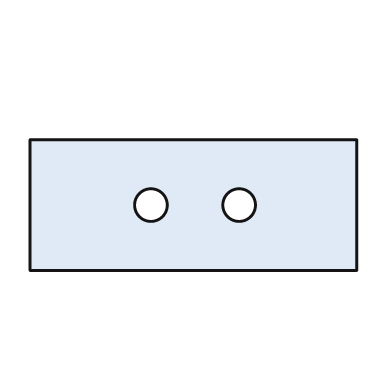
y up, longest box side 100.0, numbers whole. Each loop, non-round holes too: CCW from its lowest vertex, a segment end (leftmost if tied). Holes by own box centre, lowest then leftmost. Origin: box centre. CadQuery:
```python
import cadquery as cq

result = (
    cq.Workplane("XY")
    .moveTo(-50.0, -20.0)
    .lineTo(50.0, -20.0)
    .lineTo(50.0, 20.0)
    .lineTo(-50.0, 20.0)
    .close()
    .moveTo(-13.0, 0.0)
    .circle(5.0)
    .moveTo(14.0, 0.0)
    .circle(5.0)
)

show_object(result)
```